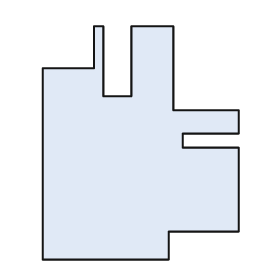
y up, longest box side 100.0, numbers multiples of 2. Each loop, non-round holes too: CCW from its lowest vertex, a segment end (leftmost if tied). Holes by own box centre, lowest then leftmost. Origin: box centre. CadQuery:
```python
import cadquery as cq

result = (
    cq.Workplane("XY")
    .moveTo(-42.0, -50.0)
    .lineTo(12.0, -50.0)
    .lineTo(12.0, -38.0)
    .lineTo(42.0, -38.0)
    .lineTo(42.0, -2.0)
    .lineTo(18.0, -2.0)
    .lineTo(18.0, 4.0)
    .lineTo(42.0, 4.0)
    .lineTo(42.0, 14.0)
    .lineTo(14.0, 14.0)
    .lineTo(14.0, 50.0)
    .lineTo(-4.0, 50.0)
    .lineTo(-4.0, 20.0)
    .lineTo(-16.0, 20.0)
    .lineTo(-16.0, 50.0)
    .lineTo(-20.0, 50.0)
    .lineTo(-20.0, 32.0)
    .lineTo(-42.0, 32.0)
    .close()
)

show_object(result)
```